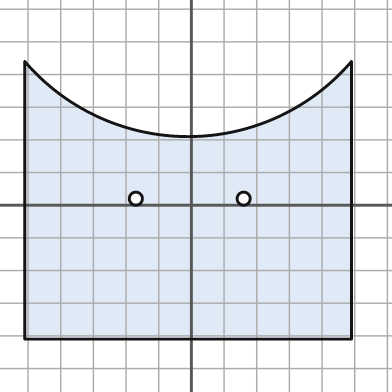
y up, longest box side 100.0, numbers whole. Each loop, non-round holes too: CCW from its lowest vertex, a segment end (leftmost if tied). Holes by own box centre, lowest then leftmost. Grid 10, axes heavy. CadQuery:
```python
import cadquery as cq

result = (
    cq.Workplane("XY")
    .moveTo(-51.0, -41.0)
    .lineTo(49.0, -41.0)
    .lineTo(49.0, 44.0)
    .threePointArc((-1.0, 21.0), (-51.0, 44.0))
    .close()
    .moveTo(-17.0, 2.0)
    .circle(2.0)
    .moveTo(16.0, 2.0)
    .circle(2.0)
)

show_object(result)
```